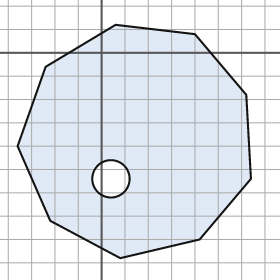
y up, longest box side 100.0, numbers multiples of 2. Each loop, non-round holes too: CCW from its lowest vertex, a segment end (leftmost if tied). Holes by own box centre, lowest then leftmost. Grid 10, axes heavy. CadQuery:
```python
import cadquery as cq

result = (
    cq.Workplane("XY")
    .moveTo(8.0, -88.0)
    .lineTo(42.0, -80.0)
    .lineTo(64.0, -54.0)
    .lineTo(62.0, -18.0)
    .lineTo(40.0, 8.0)
    .lineTo(6.0, 12.0)
    .lineTo(-24.0, -6.0)
    .lineTo(-36.0, -40.0)
    .lineTo(-22.0, -72.0)
    .close()
    .moveTo(4.0, -54.0)
    .circle(8.0)
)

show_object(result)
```